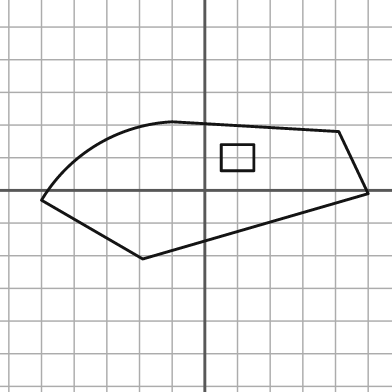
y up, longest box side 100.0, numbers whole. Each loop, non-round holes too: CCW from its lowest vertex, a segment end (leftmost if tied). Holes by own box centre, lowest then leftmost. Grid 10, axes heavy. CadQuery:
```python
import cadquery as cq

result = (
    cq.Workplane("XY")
    .moveTo(-19.0, -21.0)
    .lineTo(50.0, -1.0)
    .lineTo(41.0, 18.0)
    .lineTo(-10.0, 21.0)
    .threePointArc((-33.0, 14.0), (-50.0, -3.0))
    .close()
    .moveTo(5.0, 6.0)
    .lineTo(15.0, 6.0)
    .lineTo(15.0, 14.0)
    .lineTo(5.0, 14.0)
    .close()
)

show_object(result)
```